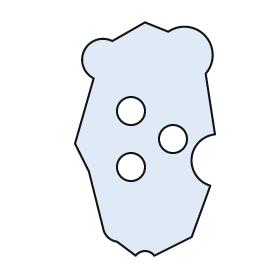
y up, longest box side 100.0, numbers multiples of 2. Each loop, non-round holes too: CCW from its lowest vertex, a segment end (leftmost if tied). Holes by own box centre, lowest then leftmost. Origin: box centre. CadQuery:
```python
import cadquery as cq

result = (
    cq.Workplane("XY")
    .moveTo(-4.0, -50.0)
    .threePointArc((0.0, -48.0), (4.0, -50.0))
    .lineTo(20.0, -42.0)
    .lineTo(28.0, -20.0)
    .threePointArc((20.0, -8.0), (30.0, 2.0))
    .lineTo(26.0, 28.0)
    .threePointArc((26.0, 44.0), (10.0, 46.0))
    .lineTo(0.0, 50.0)
    .lineTo(-14.0, 42.0)
    .threePointArc((-26.0, 38.0), (-22.0, 26.0))
    .lineTo(-30.0, -2.0)
    .lineTo(-24.0, -14.0)
    .lineTo(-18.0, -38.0)
    .threePointArc((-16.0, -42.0), (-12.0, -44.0))
    .close()
    .moveTo(-6.0, -12.0)
    .circle(6.0)
    .moveTo(12.0, 0.0)
    .circle(6.0)
    .moveTo(-6.0, 12.0)
    .circle(6.0)
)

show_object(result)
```